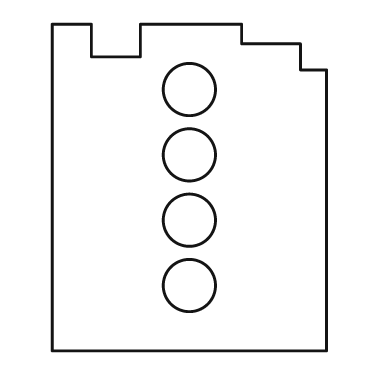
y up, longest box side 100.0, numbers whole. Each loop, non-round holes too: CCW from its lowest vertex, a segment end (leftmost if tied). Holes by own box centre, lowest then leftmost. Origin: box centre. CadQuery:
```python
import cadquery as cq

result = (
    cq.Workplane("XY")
    .moveTo(-42.0, -50.0)
    .lineTo(42.0, -50.0)
    .lineTo(42.0, 36.0)
    .lineTo(34.0, 36.0)
    .lineTo(34.0, 44.0)
    .lineTo(16.0, 44.0)
    .lineTo(16.0, 50.0)
    .lineTo(-15.0, 50.0)
    .lineTo(-15.0, 40.0)
    .lineTo(-30.0, 40.0)
    .lineTo(-30.0, 50.0)
    .lineTo(-42.0, 50.0)
    .close()
    .moveTo(0.0, -30.0)
    .circle(8.0)
    .moveTo(0.0, -10.0)
    .circle(8.0)
    .moveTo(0.0, 10.0)
    .circle(8.0)
    .moveTo(0.0, 30.0)
    .circle(8.0)
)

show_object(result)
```